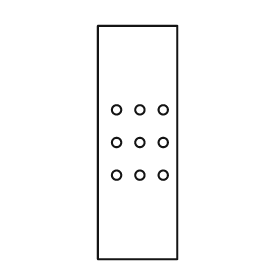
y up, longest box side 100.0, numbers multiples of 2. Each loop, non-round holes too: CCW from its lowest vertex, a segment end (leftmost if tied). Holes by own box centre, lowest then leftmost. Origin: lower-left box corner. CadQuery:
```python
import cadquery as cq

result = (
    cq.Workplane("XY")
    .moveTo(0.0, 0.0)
    .lineTo(34.0, 0.0)
    .lineTo(34.0, 100.0)
    .lineTo(0.0, 100.0)
    .close()
    .moveTo(8.0, 36.0)
    .circle(2.0)
    .moveTo(18.0, 36.0)
    .circle(2.0)
    .moveTo(28.0, 36.0)
    .circle(2.0)
    .moveTo(8.0, 50.0)
    .circle(2.0)
    .moveTo(18.0, 50.0)
    .circle(2.0)
    .moveTo(28.0, 50.0)
    .circle(2.0)
    .moveTo(8.0, 64.0)
    .circle(2.0)
    .moveTo(18.0, 64.0)
    .circle(2.0)
    .moveTo(28.0, 64.0)
    .circle(2.0)
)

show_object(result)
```